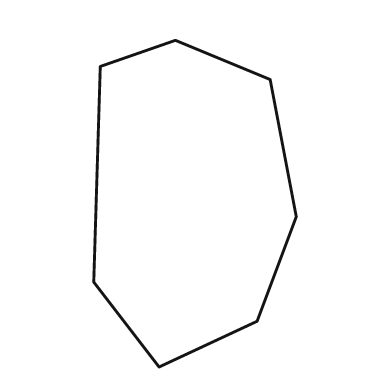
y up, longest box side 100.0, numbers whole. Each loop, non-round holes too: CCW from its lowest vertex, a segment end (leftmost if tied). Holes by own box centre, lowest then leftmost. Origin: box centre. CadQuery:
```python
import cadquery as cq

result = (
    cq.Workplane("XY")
    .moveTo(-11.0, -50.0)
    .lineTo(19.0, -36.0)
    .lineTo(31.0, -4.0)
    .lineTo(23.0, 38.0)
    .lineTo(-6.0, 50.0)
    .lineTo(-29.0, 42.0)
    .lineTo(-31.0, -24.0)
    .close()
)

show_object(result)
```